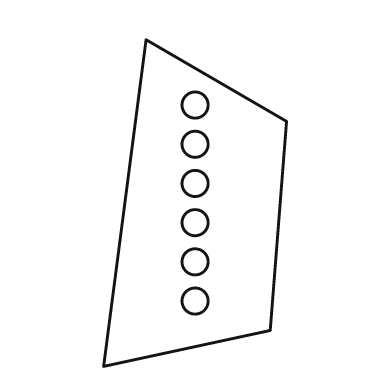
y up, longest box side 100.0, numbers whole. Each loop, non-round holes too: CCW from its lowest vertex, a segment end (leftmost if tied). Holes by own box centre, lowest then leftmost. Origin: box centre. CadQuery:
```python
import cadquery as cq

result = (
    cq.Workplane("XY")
    .moveTo(-28.0, -50.0)
    .lineTo(23.0, -39.0)
    .lineTo(28.0, 25.0)
    .lineTo(-15.0, 50.0)
    .close()
    .moveTo(0.0, -30.0)
    .circle(4.0)
    .moveTo(0.0, -18.0)
    .circle(4.0)
    .moveTo(0.0, -6.0)
    .circle(4.0)
    .moveTo(0.0, 6.0)
    .circle(4.0)
    .moveTo(0.0, 18.0)
    .circle(4.0)
    .moveTo(0.0, 30.0)
    .circle(4.0)
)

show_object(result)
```